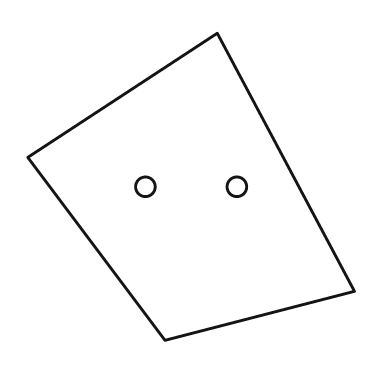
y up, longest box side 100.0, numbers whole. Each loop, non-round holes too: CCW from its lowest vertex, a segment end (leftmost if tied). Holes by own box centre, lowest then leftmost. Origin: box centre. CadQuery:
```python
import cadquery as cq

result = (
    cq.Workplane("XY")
    .moveTo(-8.0, -47.0)
    .lineTo(50.0, -32.0)
    .lineTo(8.0, 47.0)
    .lineTo(-50.0, 9.0)
    .close()
    .moveTo(-14.0, 0.0)
    .circle(3.0)
    .moveTo(14.0, 0.0)
    .circle(3.0)
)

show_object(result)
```